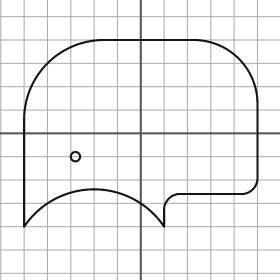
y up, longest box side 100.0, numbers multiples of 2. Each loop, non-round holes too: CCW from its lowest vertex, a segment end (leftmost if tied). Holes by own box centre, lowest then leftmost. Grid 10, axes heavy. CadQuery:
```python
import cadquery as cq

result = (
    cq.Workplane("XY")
    .moveTo(-50.0, -40.0)
    .threePointArc((-20.0, -24.0), (10.0, -40.0))
    .lineTo(10.0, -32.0)
    .threePointArc((12.0, -28.0), (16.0, -26.0))
    .lineTo(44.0, -26.0)
    .threePointArc((48.0, -24.0), (50.0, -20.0))
    .lineTo(50.0, 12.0)
    .threePointArc((42.0, 32.0), (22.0, 40.0))
    .lineTo(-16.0, 40.0)
    .threePointArc((-40.0, 30.0), (-50.0, 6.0))
    .close()
    .moveTo(-28.0, -10.0)
    .circle(2.0)
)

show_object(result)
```